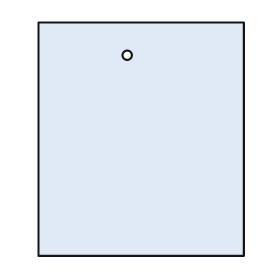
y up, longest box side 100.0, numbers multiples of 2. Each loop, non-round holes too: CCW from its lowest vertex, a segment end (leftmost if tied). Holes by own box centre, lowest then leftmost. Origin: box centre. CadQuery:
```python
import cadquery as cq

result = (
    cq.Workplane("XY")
    .moveTo(-44.0, -50.0)
    .lineTo(44.0, -50.0)
    .lineTo(44.0, 50.0)
    .lineTo(-44.0, 50.0)
    .close()
    .moveTo(-6.0, 36.0)
    .circle(2.0)
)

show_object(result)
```